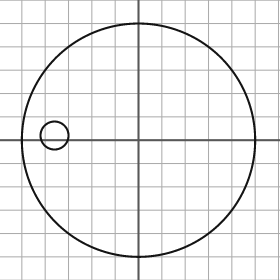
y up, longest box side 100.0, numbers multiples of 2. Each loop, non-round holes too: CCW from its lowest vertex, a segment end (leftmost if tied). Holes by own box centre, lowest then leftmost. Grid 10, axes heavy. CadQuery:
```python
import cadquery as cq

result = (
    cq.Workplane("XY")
    .moveTo(0.0, 0.0)
    .circle(50.0)
    .moveTo(-36.0, 2.0)
    .circle(6.0)
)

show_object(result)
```